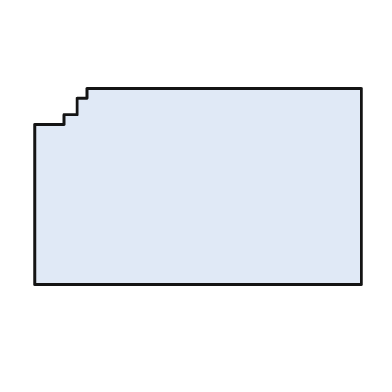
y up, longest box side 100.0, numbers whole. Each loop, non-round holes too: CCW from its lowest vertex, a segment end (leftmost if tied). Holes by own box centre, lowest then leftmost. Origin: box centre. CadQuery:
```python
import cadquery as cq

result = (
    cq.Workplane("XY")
    .moveTo(-50.0, -30.0)
    .lineTo(50.0, -30.0)
    .lineTo(50.0, 30.0)
    .lineTo(-34.0, 30.0)
    .lineTo(-34.0, 27.0)
    .lineTo(-37.0, 27.0)
    .lineTo(-37.0, 22.0)
    .lineTo(-41.0, 22.0)
    .lineTo(-41.0, 19.0)
    .lineTo(-50.0, 19.0)
    .close()
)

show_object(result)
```